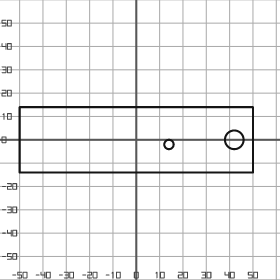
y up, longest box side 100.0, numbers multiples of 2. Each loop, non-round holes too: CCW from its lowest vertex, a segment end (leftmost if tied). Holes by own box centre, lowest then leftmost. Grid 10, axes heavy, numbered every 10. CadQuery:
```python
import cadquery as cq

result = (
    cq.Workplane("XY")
    .moveTo(-50.0, -14.0)
    .lineTo(50.0, -14.0)
    .lineTo(50.0, 14.0)
    .lineTo(-50.0, 14.0)
    .close()
    .moveTo(14.0, -2.0)
    .circle(2.0)
    .moveTo(42.0, 0.0)
    .circle(4.0)
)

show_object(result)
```